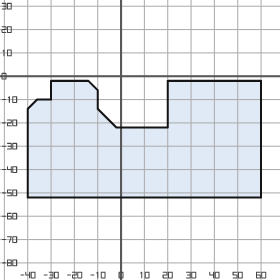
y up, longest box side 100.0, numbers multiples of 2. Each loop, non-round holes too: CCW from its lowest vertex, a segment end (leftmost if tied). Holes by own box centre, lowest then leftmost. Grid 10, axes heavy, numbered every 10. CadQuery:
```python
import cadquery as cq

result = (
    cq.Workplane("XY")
    .moveTo(-40.0, -52.0)
    .lineTo(60.0, -52.0)
    .lineTo(60.0, -2.0)
    .lineTo(20.0, -2.0)
    .lineTo(20.0, -22.0)
    .lineTo(-2.0, -22.0)
    .lineTo(-10.0, -14.0)
    .lineTo(-10.0, -6.0)
    .lineTo(-14.0, -2.0)
    .lineTo(-30.0, -2.0)
    .lineTo(-30.0, -10.0)
    .lineTo(-36.0, -10.0)
    .lineTo(-40.0, -14.0)
    .close()
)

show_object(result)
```